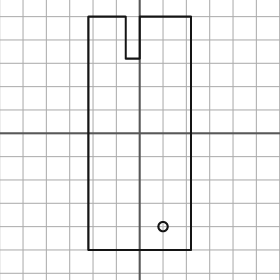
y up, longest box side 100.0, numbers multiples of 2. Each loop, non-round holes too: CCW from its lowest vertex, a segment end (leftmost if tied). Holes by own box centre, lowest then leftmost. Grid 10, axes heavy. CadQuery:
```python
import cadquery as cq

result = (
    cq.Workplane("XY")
    .moveTo(-22.0, -50.0)
    .lineTo(22.0, -50.0)
    .lineTo(22.0, 50.0)
    .lineTo(0.0, 50.0)
    .lineTo(0.0, 32.0)
    .lineTo(-6.0, 32.0)
    .lineTo(-6.0, 50.0)
    .lineTo(-22.0, 50.0)
    .close()
    .moveTo(10.0, -40.0)
    .circle(2.0)
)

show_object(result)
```